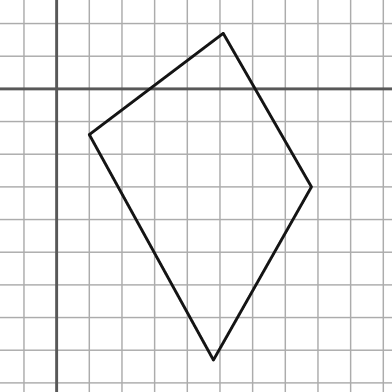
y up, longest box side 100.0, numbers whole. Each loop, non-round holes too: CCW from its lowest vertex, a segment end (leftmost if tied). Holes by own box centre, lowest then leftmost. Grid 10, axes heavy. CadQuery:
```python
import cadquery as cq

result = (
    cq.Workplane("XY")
    .moveTo(48.0, -83.0)
    .lineTo(78.0, -30.0)
    .lineTo(51.0, 17.0)
    .lineTo(10.0, -14.0)
    .close()
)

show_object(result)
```